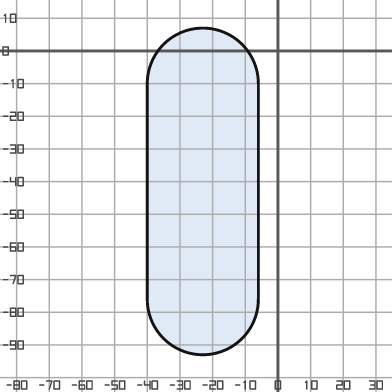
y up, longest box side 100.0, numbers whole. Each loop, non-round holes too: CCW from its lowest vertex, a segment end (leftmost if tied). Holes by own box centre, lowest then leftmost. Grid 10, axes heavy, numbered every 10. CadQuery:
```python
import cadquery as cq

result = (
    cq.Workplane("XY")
    .moveTo(-40.0, -76.0)
    .threePointArc((-23.0, -93.0), (-6.0, -76.0))
    .lineTo(-6.0, -10.0)
    .threePointArc((-23.0, 7.0), (-40.0, -10.0))
    .close()
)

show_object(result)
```